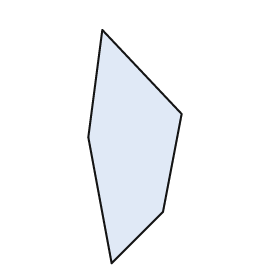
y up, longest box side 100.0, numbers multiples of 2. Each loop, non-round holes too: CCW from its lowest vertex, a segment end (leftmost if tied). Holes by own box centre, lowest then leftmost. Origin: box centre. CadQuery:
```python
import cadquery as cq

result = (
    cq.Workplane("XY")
    .moveTo(-10.0, -50.0)
    .lineTo(12.0, -28.0)
    .lineTo(20.0, 14.0)
    .lineTo(-14.0, 50.0)
    .lineTo(-20.0, 4.0)
    .close()
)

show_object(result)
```